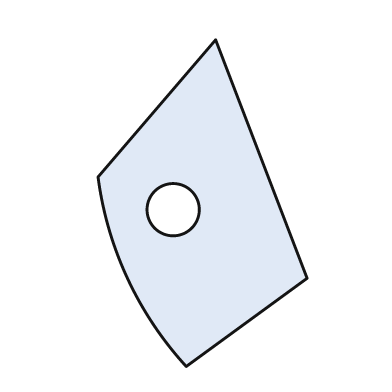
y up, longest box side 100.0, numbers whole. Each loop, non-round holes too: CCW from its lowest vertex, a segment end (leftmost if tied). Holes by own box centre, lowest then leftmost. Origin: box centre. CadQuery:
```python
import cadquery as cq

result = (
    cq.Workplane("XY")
    .moveTo(-5.0, -50.0)
    .lineTo(32.0, -23.0)
    .lineTo(4.0, 50.0)
    .lineTo(-32.0, 8.0)
    .threePointArc((-23.0, -23.0), (-5.0, -50.0))
    .close()
    .moveTo(-9.0, -2.0)
    .circle(8.0)
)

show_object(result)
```